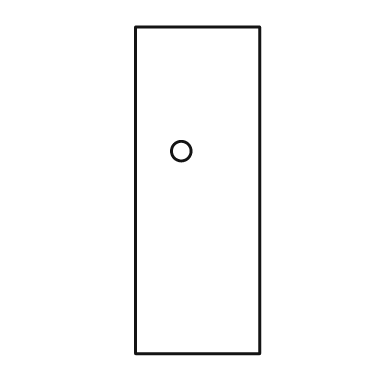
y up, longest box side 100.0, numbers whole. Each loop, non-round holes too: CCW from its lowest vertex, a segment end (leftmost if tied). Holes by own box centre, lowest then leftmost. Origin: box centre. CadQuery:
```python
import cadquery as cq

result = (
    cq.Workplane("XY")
    .moveTo(-19.0, -50.0)
    .lineTo(19.0, -50.0)
    .lineTo(19.0, 50.0)
    .lineTo(-19.0, 50.0)
    .close()
    .moveTo(-5.0, 12.0)
    .circle(3.0)
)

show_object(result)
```